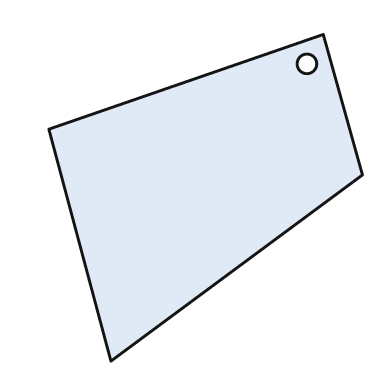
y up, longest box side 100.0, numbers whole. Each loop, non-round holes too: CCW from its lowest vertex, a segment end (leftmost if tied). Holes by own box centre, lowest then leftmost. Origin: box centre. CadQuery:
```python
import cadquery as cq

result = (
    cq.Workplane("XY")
    .moveTo(-29.0, -50.0)
    .lineTo(48.0, 7.0)
    .lineTo(36.0, 50.0)
    .lineTo(-48.0, 21.0)
    .close()
    .moveTo(31.0, 41.0)
    .circle(3.0)
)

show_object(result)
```